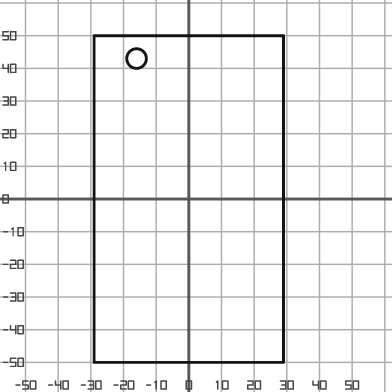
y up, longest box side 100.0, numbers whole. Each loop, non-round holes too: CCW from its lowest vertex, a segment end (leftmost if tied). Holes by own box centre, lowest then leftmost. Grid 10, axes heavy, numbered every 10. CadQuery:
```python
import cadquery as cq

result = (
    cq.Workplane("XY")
    .moveTo(-29.0, -50.0)
    .lineTo(29.0, -50.0)
    .lineTo(29.0, 50.0)
    .lineTo(-29.0, 50.0)
    .close()
    .moveTo(-16.0, 43.0)
    .circle(3.0)
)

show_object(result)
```